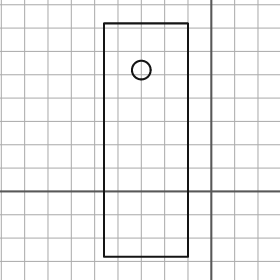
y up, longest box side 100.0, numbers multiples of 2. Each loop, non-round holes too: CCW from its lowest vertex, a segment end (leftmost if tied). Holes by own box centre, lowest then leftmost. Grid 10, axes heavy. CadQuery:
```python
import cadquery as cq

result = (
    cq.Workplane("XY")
    .moveTo(-46.0, -28.0)
    .lineTo(-10.0, -28.0)
    .lineTo(-10.0, 72.0)
    .lineTo(-46.0, 72.0)
    .close()
    .moveTo(-30.0, 52.0)
    .circle(4.0)
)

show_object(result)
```